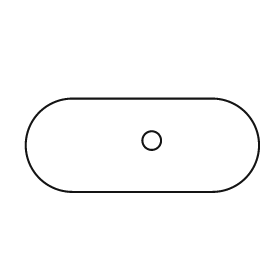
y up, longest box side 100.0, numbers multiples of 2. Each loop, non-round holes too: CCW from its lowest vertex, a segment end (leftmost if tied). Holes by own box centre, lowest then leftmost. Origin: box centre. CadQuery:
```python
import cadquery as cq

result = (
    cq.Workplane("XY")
    .moveTo(-30.0, -20.0)
    .lineTo(30.0, -20.0)
    .threePointArc((50.0, 0.0), (30.0, 20.0))
    .lineTo(-30.0, 20.0)
    .threePointArc((-50.0, 0.0), (-30.0, -20.0))
    .close()
    .moveTo(4.0, 2.0)
    .circle(4.0)
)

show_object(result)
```